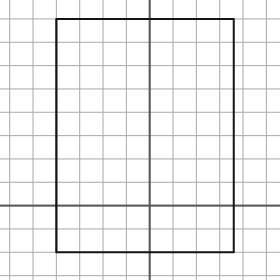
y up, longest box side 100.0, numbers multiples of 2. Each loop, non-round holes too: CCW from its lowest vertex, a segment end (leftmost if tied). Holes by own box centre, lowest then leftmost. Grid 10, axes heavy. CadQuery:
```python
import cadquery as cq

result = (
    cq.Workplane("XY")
    .moveTo(-40.0, -20.0)
    .lineTo(36.0, -20.0)
    .lineTo(36.0, 80.0)
    .lineTo(-40.0, 80.0)
    .close()
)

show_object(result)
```